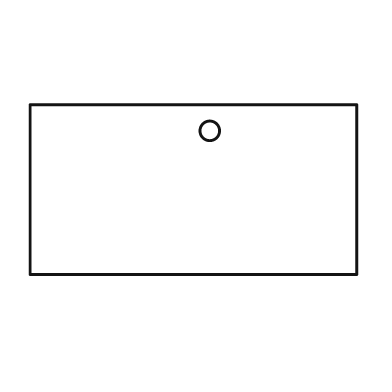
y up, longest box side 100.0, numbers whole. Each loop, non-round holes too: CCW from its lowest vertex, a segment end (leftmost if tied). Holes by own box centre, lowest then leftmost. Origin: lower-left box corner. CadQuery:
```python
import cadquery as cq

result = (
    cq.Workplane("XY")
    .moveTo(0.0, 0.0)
    .lineTo(100.0, 0.0)
    .lineTo(100.0, 52.0)
    .lineTo(0.0, 52.0)
    .close()
    .moveTo(55.0, 44.0)
    .circle(3.0)
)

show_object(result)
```